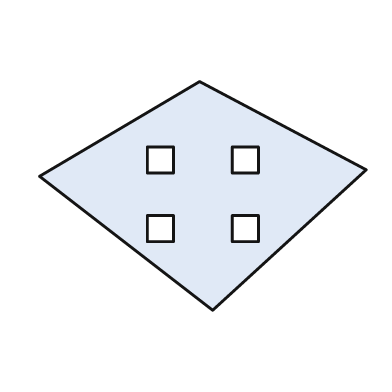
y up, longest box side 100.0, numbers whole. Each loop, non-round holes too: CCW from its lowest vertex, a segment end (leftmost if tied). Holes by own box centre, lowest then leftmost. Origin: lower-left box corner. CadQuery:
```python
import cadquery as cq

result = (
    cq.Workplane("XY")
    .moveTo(53.0, 0.0)
    .lineTo(100.0, 43.0)
    .lineTo(49.0, 70.0)
    .lineTo(0.0, 41.0)
    .close()
    .moveTo(33.0, 21.0)
    .lineTo(41.0, 21.0)
    .lineTo(41.0, 29.0)
    .lineTo(33.0, 29.0)
    .close()
    .moveTo(59.0, 21.0)
    .lineTo(67.0, 21.0)
    .lineTo(67.0, 29.0)
    .lineTo(59.0, 29.0)
    .close()
    .moveTo(33.0, 42.0)
    .lineTo(41.0, 42.0)
    .lineTo(41.0, 50.0)
    .lineTo(33.0, 50.0)
    .close()
    .moveTo(59.0, 42.0)
    .lineTo(67.0, 42.0)
    .lineTo(67.0, 50.0)
    .lineTo(59.0, 50.0)
    .close()
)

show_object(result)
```